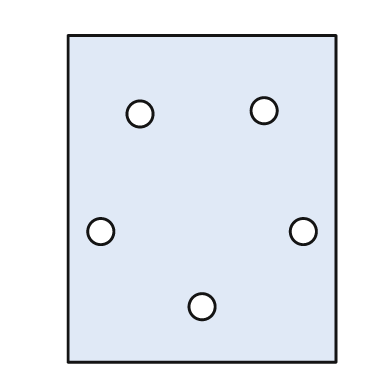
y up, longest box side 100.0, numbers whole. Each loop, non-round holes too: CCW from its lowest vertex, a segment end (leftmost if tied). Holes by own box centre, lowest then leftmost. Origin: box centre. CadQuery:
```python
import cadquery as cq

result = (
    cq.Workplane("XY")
    .moveTo(-41.0, -50.0)
    .lineTo(41.0, -50.0)
    .lineTo(41.0, 50.0)
    .lineTo(-41.0, 50.0)
    .close()
    .moveTo(0.0, -33.0)
    .circle(4.0)
    .moveTo(-31.0, -10.0)
    .circle(4.0)
    .moveTo(31.0, -10.0)
    .circle(4.0)
    .moveTo(-19.0, 26.0)
    .circle(4.0)
    .moveTo(19.0, 27.0)
    .circle(4.0)
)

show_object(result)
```